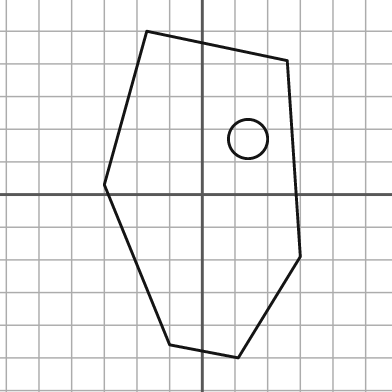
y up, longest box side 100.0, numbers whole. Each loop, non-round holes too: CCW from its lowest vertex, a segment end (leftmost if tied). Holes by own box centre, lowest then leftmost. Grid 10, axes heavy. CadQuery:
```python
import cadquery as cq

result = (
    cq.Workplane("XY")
    .moveTo(11.0, -50.0)
    .lineTo(30.0, -19.0)
    .lineTo(26.0, 41.0)
    .lineTo(-17.0, 50.0)
    .lineTo(-30.0, 3.0)
    .lineTo(-10.0, -46.0)
    .close()
    .moveTo(14.0, 17.0)
    .circle(6.0)
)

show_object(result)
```